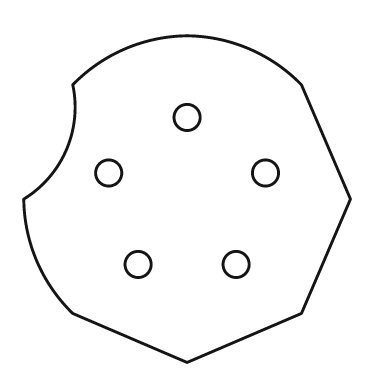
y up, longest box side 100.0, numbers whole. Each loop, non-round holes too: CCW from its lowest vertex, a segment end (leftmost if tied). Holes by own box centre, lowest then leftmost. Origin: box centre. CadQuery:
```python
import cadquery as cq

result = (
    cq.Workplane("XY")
    .moveTo(0.0, -50.0)
    .lineTo(35.0, -35.0)
    .lineTo(50.0, 0.0)
    .lineTo(35.0, 35.0)
    .threePointArc((19.0, 46.0), (0.0, 50.0))
    .threePointArc((-19.0, 46.0), (-35.0, 35.0))
    .threePointArc((-37.0, 15.0), (-50.0, 0.0))
    .threePointArc((-46.0, -19.0), (-35.0, -35.0))
    .close()
    .moveTo(-15.0, -20.0)
    .circle(4.0)
    .moveTo(15.0, -20.0)
    .circle(4.0)
    .moveTo(-24.0, 8.0)
    .circle(4.0)
    .moveTo(24.0, 8.0)
    .circle(4.0)
    .moveTo(0.0, 25.0)
    .circle(4.0)
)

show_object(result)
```